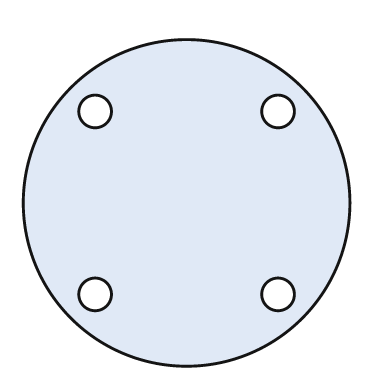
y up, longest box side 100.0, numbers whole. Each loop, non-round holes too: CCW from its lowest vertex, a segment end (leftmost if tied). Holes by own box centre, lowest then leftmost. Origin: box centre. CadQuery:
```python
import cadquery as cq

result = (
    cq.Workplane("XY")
    .moveTo(0.0, 0.0)
    .circle(50.0)
    .moveTo(-28.0, -28.0)
    .circle(5.0)
    .moveTo(28.0, -28.0)
    .circle(5.0)
    .moveTo(-28.0, 28.0)
    .circle(5.0)
    .moveTo(28.0, 28.0)
    .circle(5.0)
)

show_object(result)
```